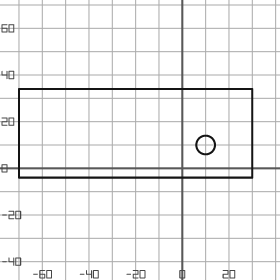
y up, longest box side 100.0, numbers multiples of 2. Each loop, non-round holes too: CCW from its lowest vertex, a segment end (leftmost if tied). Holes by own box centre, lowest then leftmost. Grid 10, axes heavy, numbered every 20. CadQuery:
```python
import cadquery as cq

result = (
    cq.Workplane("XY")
    .moveTo(-70.0, -4.0)
    .lineTo(30.0, -4.0)
    .lineTo(30.0, 34.0)
    .lineTo(-70.0, 34.0)
    .close()
    .moveTo(10.0, 10.0)
    .circle(4.0)
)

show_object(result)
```